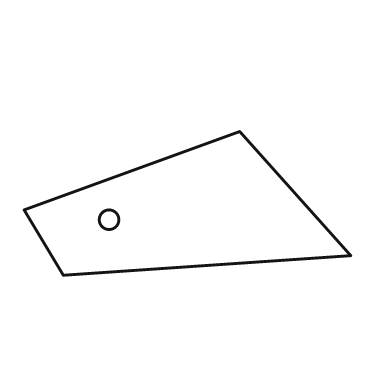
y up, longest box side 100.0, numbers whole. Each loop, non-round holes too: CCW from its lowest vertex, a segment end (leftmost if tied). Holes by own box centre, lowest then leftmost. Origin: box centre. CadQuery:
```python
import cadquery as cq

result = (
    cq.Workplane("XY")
    .moveTo(-38.0, -22.0)
    .lineTo(50.0, -16.0)
    .lineTo(16.0, 22.0)
    .lineTo(-50.0, -2.0)
    .close()
    .moveTo(-24.0, -5.0)
    .circle(3.0)
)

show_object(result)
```